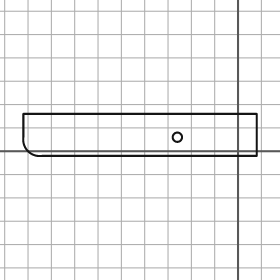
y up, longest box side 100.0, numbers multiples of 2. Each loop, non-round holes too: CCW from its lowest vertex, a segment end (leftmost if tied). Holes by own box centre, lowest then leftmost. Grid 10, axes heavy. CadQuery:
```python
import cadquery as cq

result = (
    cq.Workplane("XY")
    .moveTo(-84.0, -2.0)
    .lineTo(8.0, -2.0)
    .lineTo(8.0, 16.0)
    .lineTo(-92.0, 16.0)
    .lineTo(-92.0, 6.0)
    .threePointArc((-90.0, 0.0), (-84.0, -2.0))
    .close()
    .moveTo(-26.0, 6.0)
    .circle(2.0)
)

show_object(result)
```